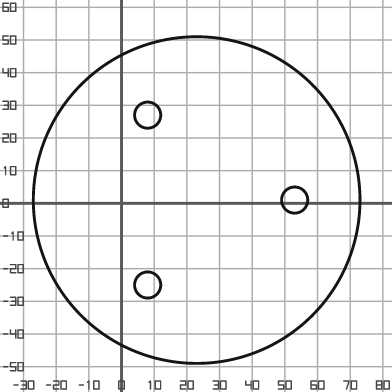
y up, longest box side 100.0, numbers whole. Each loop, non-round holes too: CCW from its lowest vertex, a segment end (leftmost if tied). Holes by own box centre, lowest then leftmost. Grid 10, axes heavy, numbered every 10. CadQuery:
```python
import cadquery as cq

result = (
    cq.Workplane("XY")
    .moveTo(23.0, 1.0)
    .circle(50.0)
    .moveTo(8.0, -25.0)
    .circle(4.0)
    .moveTo(53.0, 1.0)
    .circle(4.0)
    .moveTo(8.0, 27.0)
    .circle(4.0)
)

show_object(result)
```